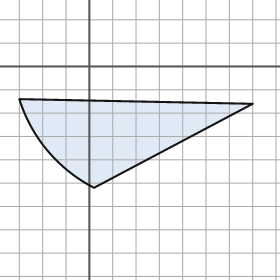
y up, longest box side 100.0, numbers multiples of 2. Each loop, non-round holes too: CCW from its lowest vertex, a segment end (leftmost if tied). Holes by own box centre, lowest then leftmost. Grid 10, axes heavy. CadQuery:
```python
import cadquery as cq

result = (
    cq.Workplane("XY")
    .moveTo(2.0, -52.0)
    .lineTo(70.0, -16.0)
    .lineTo(-30.0, -14.0)
    .threePointArc((-18.0, -36.0), (2.0, -52.0))
    .close()
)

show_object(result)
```